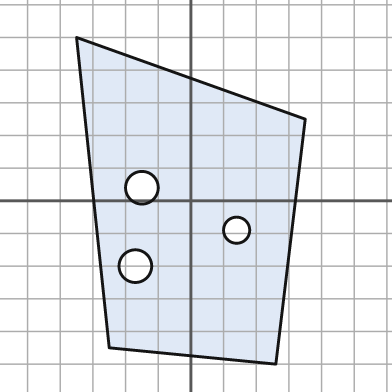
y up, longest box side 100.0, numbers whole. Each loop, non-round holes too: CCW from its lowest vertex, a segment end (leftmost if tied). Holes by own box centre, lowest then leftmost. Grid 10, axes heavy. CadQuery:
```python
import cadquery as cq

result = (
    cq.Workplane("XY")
    .moveTo(26.0, -50.0)
    .lineTo(35.0, 25.0)
    .lineTo(-35.0, 50.0)
    .lineTo(-25.0, -45.0)
    .close()
    .moveTo(-17.0, -20.0)
    .circle(5.0)
    .moveTo(14.0, -9.0)
    .circle(4.0)
    .moveTo(-15.0, 4.0)
    .circle(5.0)
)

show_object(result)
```